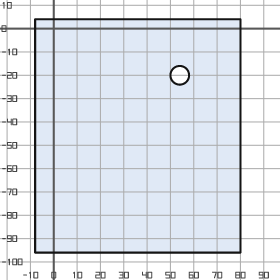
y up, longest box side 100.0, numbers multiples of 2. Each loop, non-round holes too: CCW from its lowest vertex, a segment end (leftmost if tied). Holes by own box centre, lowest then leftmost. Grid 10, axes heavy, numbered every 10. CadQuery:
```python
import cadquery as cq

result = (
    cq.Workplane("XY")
    .moveTo(-8.0, -96.0)
    .lineTo(80.0, -96.0)
    .lineTo(80.0, 4.0)
    .lineTo(-8.0, 4.0)
    .close()
    .moveTo(54.0, -20.0)
    .circle(4.0)
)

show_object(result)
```